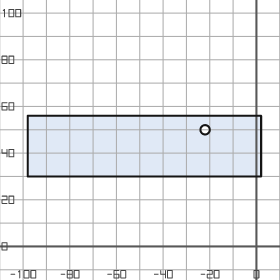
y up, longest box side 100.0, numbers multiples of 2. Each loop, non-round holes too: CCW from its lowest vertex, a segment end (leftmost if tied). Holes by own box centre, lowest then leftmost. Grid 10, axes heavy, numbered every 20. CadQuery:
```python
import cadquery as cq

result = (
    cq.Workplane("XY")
    .moveTo(-98.0, 30.0)
    .lineTo(2.0, 30.0)
    .lineTo(2.0, 56.0)
    .lineTo(-98.0, 56.0)
    .close()
    .moveTo(-22.0, 50.0)
    .circle(2.0)
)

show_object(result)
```